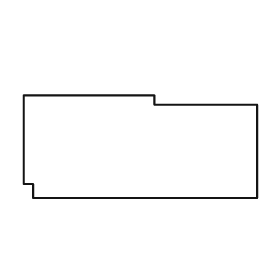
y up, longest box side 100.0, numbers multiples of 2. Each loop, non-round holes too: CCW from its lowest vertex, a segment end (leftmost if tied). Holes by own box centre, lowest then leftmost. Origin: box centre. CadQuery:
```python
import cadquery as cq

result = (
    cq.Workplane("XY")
    .moveTo(-46.0, -22.0)
    .lineTo(50.0, -22.0)
    .lineTo(50.0, 18.0)
    .lineTo(6.0, 18.0)
    .lineTo(6.0, 22.0)
    .lineTo(-50.0, 22.0)
    .lineTo(-50.0, -16.0)
    .lineTo(-46.0, -16.0)
    .close()
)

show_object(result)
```